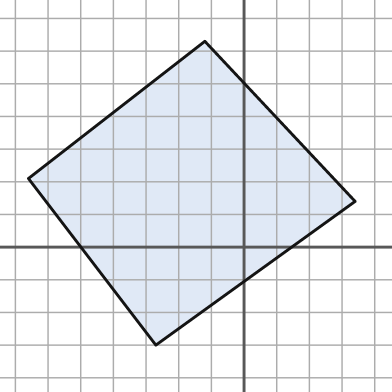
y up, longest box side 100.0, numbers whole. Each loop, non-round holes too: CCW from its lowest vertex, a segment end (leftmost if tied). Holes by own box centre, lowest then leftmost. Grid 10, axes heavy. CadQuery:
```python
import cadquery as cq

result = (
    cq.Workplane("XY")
    .moveTo(-27.0, -30.0)
    .lineTo(34.0, 14.0)
    .lineTo(-12.0, 63.0)
    .lineTo(-66.0, 21.0)
    .close()
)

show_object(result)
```